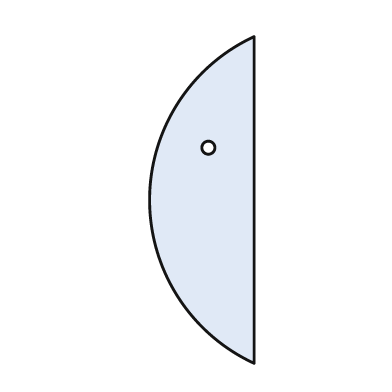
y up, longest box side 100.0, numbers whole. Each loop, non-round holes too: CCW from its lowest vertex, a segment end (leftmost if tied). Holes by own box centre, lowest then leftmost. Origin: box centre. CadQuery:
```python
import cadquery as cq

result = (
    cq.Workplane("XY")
    .moveTo(16.0, -50.0)
    .lineTo(16.0, 50.0)
    .threePointArc((-16.0, 0.0), (16.0, -50.0))
    .close()
    .moveTo(2.0, 16.0)
    .circle(2.0)
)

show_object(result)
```